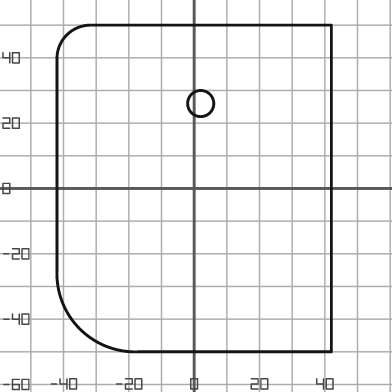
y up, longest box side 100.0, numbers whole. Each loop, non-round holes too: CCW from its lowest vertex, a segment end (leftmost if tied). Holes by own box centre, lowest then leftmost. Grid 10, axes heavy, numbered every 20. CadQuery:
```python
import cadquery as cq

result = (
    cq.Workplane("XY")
    .moveTo(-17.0, -50.0)
    .lineTo(42.0, -50.0)
    .lineTo(42.0, 50.0)
    .lineTo(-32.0, 50.0)
    .threePointArc((-39.0, 47.0), (-42.0, 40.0))
    .lineTo(-42.0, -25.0)
    .threePointArc((-35.0, -43.0), (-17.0, -50.0))
    .close()
    .moveTo(2.0, 26.0)
    .circle(4.0)
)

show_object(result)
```